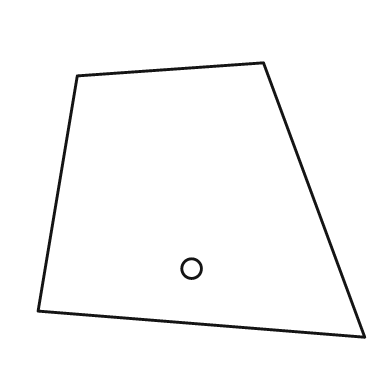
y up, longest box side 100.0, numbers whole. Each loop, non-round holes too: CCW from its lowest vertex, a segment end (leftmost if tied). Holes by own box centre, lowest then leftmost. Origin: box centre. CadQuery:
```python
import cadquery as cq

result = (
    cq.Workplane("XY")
    .moveTo(50.0, -42.0)
    .lineTo(19.0, 42.0)
    .lineTo(-38.0, 38.0)
    .lineTo(-50.0, -34.0)
    .close()
    .moveTo(-3.0, -21.0)
    .circle(3.0)
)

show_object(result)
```